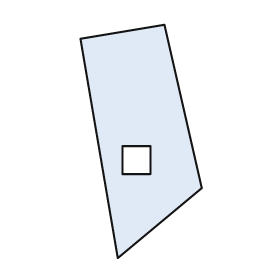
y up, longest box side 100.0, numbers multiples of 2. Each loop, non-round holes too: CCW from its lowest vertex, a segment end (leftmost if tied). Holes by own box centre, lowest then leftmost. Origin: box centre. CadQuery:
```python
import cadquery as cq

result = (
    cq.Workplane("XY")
    .moveTo(-10.0, -50.0)
    .lineTo(26.0, -20.0)
    .lineTo(10.0, 50.0)
    .lineTo(-26.0, 44.0)
    .close()
    .moveTo(-8.0, -14.0)
    .lineTo(4.0, -14.0)
    .lineTo(4.0, -2.0)
    .lineTo(-8.0, -2.0)
    .close()
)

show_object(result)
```